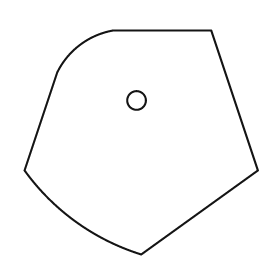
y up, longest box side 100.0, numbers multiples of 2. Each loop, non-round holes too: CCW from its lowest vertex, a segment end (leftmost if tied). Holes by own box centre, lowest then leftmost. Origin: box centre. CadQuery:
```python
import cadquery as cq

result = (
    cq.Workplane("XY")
    .moveTo(0.0, -48.0)
    .lineTo(50.0, -12.0)
    .lineTo(30.0, 48.0)
    .lineTo(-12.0, 48.0)
    .threePointArc((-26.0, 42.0), (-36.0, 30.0))
    .lineTo(-50.0, -12.0)
    .threePointArc((-28.0, -34.0), (0.0, -48.0))
    .close()
    .moveTo(-2.0, 18.0)
    .circle(4.0)
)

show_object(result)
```